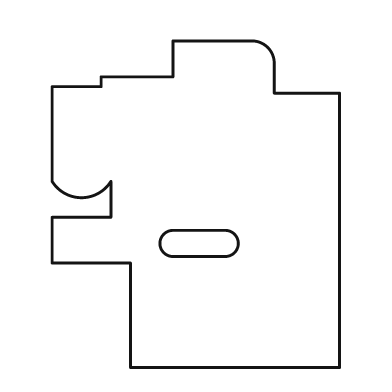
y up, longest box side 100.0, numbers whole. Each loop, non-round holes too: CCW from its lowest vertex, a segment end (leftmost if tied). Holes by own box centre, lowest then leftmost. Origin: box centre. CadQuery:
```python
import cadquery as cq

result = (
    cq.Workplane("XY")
    .moveTo(-20.0, -50.0)
    .lineTo(44.0, -50.0)
    .lineTo(44.0, 34.0)
    .lineTo(24.0, 34.0)
    .lineTo(24.0, 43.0)
    .threePointArc((22.0, 48.0), (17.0, 50.0))
    .lineTo(-7.0, 50.0)
    .lineTo(-7.0, 39.0)
    .lineTo(-29.0, 39.0)
    .lineTo(-29.0, 36.0)
    .lineTo(-44.0, 36.0)
    .lineTo(-44.0, 7.0)
    .threePointArc((-35.0, 2.0), (-26.0, 7.0))
    .lineTo(-26.0, -4.0)
    .lineTo(-44.0, -4.0)
    .lineTo(-44.0, -18.0)
    .lineTo(-20.0, -18.0)
    .close()
    .moveTo(-7.0, -16.0)
    .lineTo(9.0, -16.0)
    .threePointArc((13.0, -12.0), (9.0, -8.0))
    .lineTo(-7.0, -8.0)
    .threePointArc((-11.0, -12.0), (-7.0, -16.0))
    .close()
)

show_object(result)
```